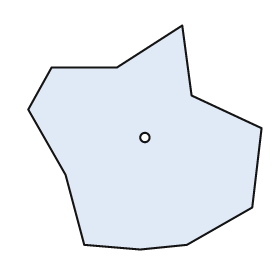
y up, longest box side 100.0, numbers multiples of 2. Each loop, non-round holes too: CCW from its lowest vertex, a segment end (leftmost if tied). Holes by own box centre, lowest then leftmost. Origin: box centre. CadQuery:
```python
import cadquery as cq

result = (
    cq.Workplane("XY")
    .moveTo(-2.0, -48.0)
    .lineTo(18.0, -46.0)
    .lineTo(46.0, -30.0)
    .lineTo(50.0, 4.0)
    .lineTo(20.0, 18.0)
    .lineTo(16.0, 48.0)
    .lineTo(-12.0, 30.0)
    .lineTo(-40.0, 30.0)
    .lineTo(-50.0, 12.0)
    .lineTo(-34.0, -16.0)
    .lineTo(-26.0, -46.0)
    .close()
    .moveTo(0.0, 0.0)
    .circle(2.0)
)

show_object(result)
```